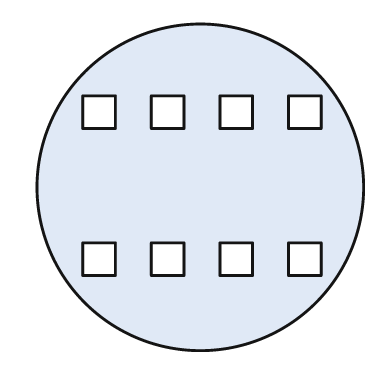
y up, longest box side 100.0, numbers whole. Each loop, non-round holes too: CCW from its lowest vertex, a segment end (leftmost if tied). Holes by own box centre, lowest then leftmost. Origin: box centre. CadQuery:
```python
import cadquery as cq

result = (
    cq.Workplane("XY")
    .moveTo(0.0, 0.0)
    .circle(50.0)
    .moveTo(-36.0, -27.0)
    .lineTo(-26.0, -27.0)
    .lineTo(-26.0, -17.0)
    .lineTo(-36.0, -17.0)
    .close()
    .moveTo(-15.0, -27.0)
    .lineTo(-5.0, -27.0)
    .lineTo(-5.0, -17.0)
    .lineTo(-15.0, -17.0)
    .close()
    .moveTo(6.0, -27.0)
    .lineTo(16.0, -27.0)
    .lineTo(16.0, -17.0)
    .lineTo(6.0, -17.0)
    .close()
    .moveTo(27.0, -27.0)
    .lineTo(37.0, -27.0)
    .lineTo(37.0, -17.0)
    .lineTo(27.0, -17.0)
    .close()
    .moveTo(-36.0, 18.0)
    .lineTo(-26.0, 18.0)
    .lineTo(-26.0, 28.0)
    .lineTo(-36.0, 28.0)
    .close()
    .moveTo(-15.0, 18.0)
    .lineTo(-5.0, 18.0)
    .lineTo(-5.0, 28.0)
    .lineTo(-15.0, 28.0)
    .close()
    .moveTo(6.0, 18.0)
    .lineTo(16.0, 18.0)
    .lineTo(16.0, 28.0)
    .lineTo(6.0, 28.0)
    .close()
    .moveTo(27.0, 18.0)
    .lineTo(37.0, 18.0)
    .lineTo(37.0, 28.0)
    .lineTo(27.0, 28.0)
    .close()
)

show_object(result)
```